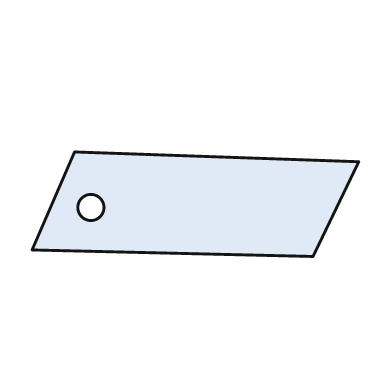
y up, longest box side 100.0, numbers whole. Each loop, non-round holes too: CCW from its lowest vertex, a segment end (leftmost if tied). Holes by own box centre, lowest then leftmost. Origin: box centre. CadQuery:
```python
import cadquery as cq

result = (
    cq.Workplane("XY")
    .moveTo(36.0, -16.0)
    .lineTo(50.0, 13.0)
    .lineTo(-37.0, 16.0)
    .lineTo(-50.0, -14.0)
    .close()
    .moveTo(-32.0, -1.0)
    .circle(4.0)
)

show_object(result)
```